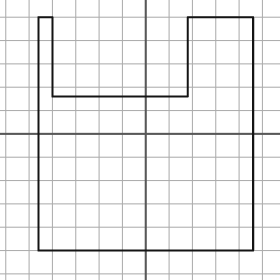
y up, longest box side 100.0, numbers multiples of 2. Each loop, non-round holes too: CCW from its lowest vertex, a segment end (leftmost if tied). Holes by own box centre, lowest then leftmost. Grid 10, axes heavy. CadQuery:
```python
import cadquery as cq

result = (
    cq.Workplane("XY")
    .moveTo(-46.0, -50.0)
    .lineTo(46.0, -50.0)
    .lineTo(46.0, 50.0)
    .lineTo(18.0, 50.0)
    .lineTo(18.0, 16.0)
    .lineTo(-40.0, 16.0)
    .lineTo(-40.0, 50.0)
    .lineTo(-46.0, 50.0)
    .close()
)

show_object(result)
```